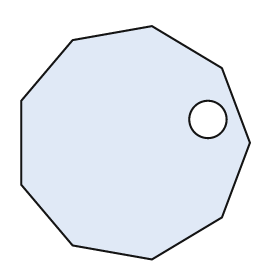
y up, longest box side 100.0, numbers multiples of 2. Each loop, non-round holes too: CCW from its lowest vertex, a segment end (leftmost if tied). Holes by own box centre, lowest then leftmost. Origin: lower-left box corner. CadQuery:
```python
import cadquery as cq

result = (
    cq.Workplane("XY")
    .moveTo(56.0, 0.0)
    .lineTo(86.0, 18.0)
    .lineTo(98.0, 50.0)
    .lineTo(86.0, 82.0)
    .lineTo(56.0, 100.0)
    .lineTo(22.0, 94.0)
    .lineTo(0.0, 68.0)
    .lineTo(0.0, 32.0)
    .lineTo(22.0, 6.0)
    .close()
    .moveTo(80.0, 60.0)
    .circle(8.0)
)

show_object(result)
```